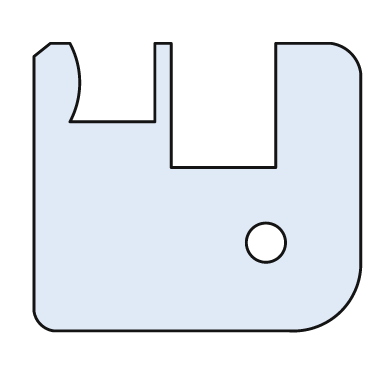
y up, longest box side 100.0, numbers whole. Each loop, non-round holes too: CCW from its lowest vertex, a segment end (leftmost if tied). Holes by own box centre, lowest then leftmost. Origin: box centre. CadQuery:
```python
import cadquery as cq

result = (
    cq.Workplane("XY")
    .moveTo(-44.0, -44.0)
    .lineTo(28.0, -44.0)
    .threePointArc((44.0, -38.0), (50.0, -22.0))
    .lineTo(50.0, 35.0)
    .threePointArc((47.0, 41.0), (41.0, 44.0))
    .lineTo(24.0, 44.0)
    .lineTo(24.0, 6.0)
    .lineTo(-8.0, 6.0)
    .lineTo(-8.0, 44.0)
    .lineTo(-13.0, 44.0)
    .lineTo(-13.0, 20.0)
    .lineTo(-39.0, 20.0)
    .threePointArc((-36.0, 32.0), (-39.0, 44.0))
    .lineTo(-45.0, 44.0)
    .lineTo(-50.0, 40.0)
    .lineTo(-50.0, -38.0)
    .threePointArc((-48.0, -42.0), (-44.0, -44.0))
    .close()
    .moveTo(21.0, -17.0)
    .circle(6.0)
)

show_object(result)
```